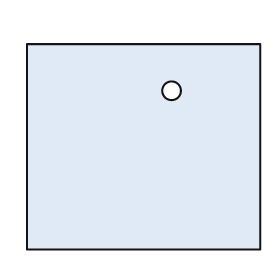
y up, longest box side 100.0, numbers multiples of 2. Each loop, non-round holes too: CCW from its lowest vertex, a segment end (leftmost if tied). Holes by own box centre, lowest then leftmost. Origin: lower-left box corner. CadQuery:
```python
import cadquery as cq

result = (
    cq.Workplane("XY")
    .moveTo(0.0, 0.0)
    .lineTo(100.0, 0.0)
    .lineTo(100.0, 88.0)
    .lineTo(0.0, 88.0)
    .close()
    .moveTo(62.0, 68.0)
    .circle(4.0)
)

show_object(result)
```